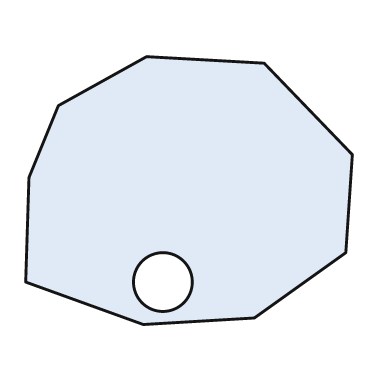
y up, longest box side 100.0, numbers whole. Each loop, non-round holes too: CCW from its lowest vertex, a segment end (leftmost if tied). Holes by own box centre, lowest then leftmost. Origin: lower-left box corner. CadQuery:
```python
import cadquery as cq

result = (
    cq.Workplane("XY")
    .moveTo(36.0, 0.0)
    .lineTo(70.0, 2.0)
    .lineTo(98.0, 22.0)
    .lineTo(100.0, 52.0)
    .lineTo(73.0, 80.0)
    .lineTo(37.0, 82.0)
    .lineTo(10.0, 67.0)
    .lineTo(1.0, 45.0)
    .lineTo(0.0, 13.0)
    .close()
    .moveTo(42.0, 13.0)
    .circle(9.0)
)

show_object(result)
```